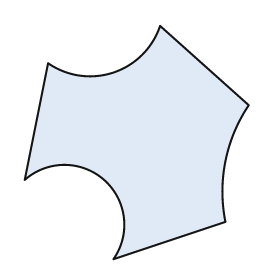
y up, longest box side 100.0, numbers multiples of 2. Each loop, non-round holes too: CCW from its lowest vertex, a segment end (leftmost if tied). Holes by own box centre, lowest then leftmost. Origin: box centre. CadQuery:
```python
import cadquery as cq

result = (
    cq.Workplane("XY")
    .moveTo(-10.0, -50.0)
    .lineTo(38.0, -34.0)
    .threePointArc((38.0, -8.0), (48.0, 16.0))
    .lineTo(10.0, 50.0)
    .threePointArc((-10.0, 30.0), (-38.0, 34.0))
    .lineTo(-48.0, -16.0)
    .threePointArc((-14.0, -16.0), (-10.0, -50.0))
    .close()
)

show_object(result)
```